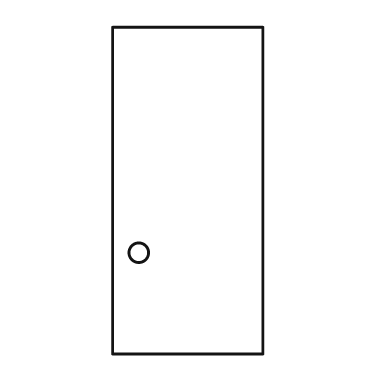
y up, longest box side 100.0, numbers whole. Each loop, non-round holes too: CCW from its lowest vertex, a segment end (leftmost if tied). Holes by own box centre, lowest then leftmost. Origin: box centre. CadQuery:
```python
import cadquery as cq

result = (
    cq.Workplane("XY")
    .moveTo(-23.0, -50.0)
    .lineTo(23.0, -50.0)
    .lineTo(23.0, 50.0)
    .lineTo(-23.0, 50.0)
    .close()
    .moveTo(-15.0, -19.0)
    .circle(3.0)
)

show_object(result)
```